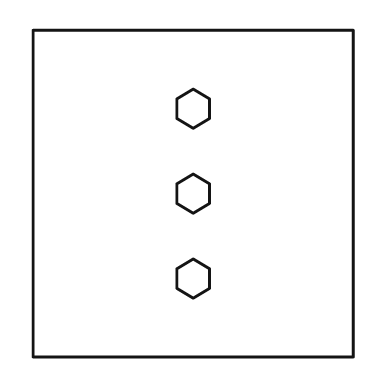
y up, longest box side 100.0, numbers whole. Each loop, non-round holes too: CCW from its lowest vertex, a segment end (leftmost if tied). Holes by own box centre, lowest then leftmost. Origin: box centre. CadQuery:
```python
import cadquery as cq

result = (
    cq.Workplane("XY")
    .moveTo(-49.0, -50.0)
    .lineTo(49.0, -50.0)
    .lineTo(49.0, 50.0)
    .lineTo(-49.0, 50.0)
    .close()
    .moveTo(0.0, -32.0)
    .lineTo(5.0, -29.0)
    .lineTo(5.0, -23.0)
    .lineTo(0.0, -20.0)
    .lineTo(-5.0, -23.0)
    .lineTo(-5.0, -29.0)
    .close()
    .moveTo(0.0, -6.0)
    .lineTo(5.0, -3.0)
    .lineTo(5.0, 3.0)
    .lineTo(0.0, 6.0)
    .lineTo(-5.0, 3.0)
    .lineTo(-5.0, -3.0)
    .close()
    .moveTo(0.0, 20.0)
    .lineTo(5.0, 23.0)
    .lineTo(5.0, 29.0)
    .lineTo(0.0, 32.0)
    .lineTo(-5.0, 29.0)
    .lineTo(-5.0, 23.0)
    .close()
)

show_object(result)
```